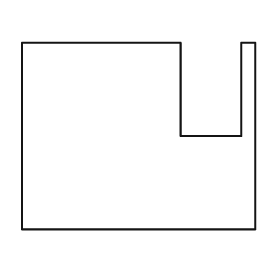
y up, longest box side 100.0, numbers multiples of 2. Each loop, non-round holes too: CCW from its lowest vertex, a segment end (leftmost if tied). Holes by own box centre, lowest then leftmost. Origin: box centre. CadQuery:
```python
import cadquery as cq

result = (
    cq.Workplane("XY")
    .moveTo(-50.0, -40.0)
    .lineTo(50.0, -40.0)
    .lineTo(50.0, 40.0)
    .lineTo(44.0, 40.0)
    .lineTo(44.0, 0.0)
    .lineTo(18.0, 0.0)
    .lineTo(18.0, 40.0)
    .lineTo(-50.0, 40.0)
    .close()
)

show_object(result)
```